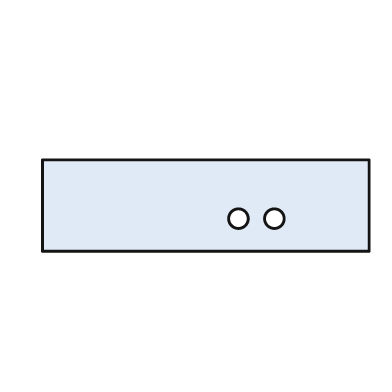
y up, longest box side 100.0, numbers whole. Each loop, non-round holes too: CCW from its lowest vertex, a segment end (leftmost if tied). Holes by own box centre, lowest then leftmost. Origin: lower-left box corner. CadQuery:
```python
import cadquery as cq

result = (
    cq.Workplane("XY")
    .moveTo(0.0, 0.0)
    .lineTo(100.0, 0.0)
    .lineTo(100.0, 28.0)
    .lineTo(0.0, 28.0)
    .close()
    .moveTo(60.0, 10.0)
    .circle(3.0)
    .moveTo(71.0, 10.0)
    .circle(3.0)
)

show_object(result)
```